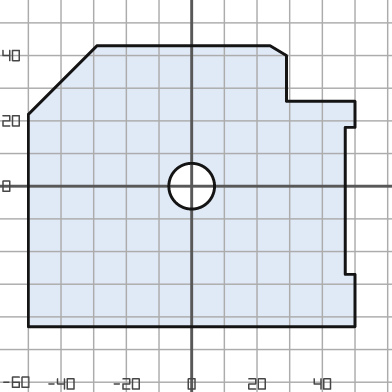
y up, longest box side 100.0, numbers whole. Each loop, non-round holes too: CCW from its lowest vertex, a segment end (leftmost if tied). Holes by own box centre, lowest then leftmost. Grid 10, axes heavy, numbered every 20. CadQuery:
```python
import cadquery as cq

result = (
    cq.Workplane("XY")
    .moveTo(-50.0, -43.0)
    .lineTo(50.0, -43.0)
    .lineTo(50.0, -27.0)
    .lineTo(47.0, -27.0)
    .lineTo(47.0, 18.0)
    .lineTo(50.0, 18.0)
    .lineTo(50.0, 26.0)
    .lineTo(29.0, 26.0)
    .lineTo(29.0, 40.0)
    .lineTo(24.0, 43.0)
    .lineTo(-29.0, 43.0)
    .lineTo(-50.0, 22.0)
    .close()
    .moveTo(0.0, 0.0)
    .circle(7.0)
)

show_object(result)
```